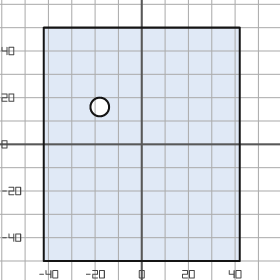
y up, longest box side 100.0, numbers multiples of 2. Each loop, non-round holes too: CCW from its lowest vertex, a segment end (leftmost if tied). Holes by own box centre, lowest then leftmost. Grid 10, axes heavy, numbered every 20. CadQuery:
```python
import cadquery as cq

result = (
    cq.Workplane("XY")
    .moveTo(-42.0, -50.0)
    .lineTo(42.0, -50.0)
    .lineTo(42.0, 50.0)
    .lineTo(-42.0, 50.0)
    .close()
    .moveTo(-18.0, 16.0)
    .circle(4.0)
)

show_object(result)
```